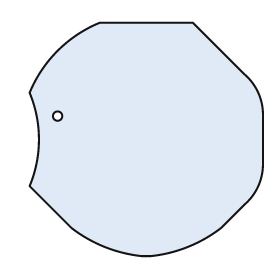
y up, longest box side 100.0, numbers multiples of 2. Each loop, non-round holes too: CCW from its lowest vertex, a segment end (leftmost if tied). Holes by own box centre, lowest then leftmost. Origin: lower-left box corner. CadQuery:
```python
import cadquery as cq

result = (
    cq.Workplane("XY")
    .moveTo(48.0, 0.0)
    .lineTo(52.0, 0.0)
    .threePointArc((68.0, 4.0), (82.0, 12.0))
    .lineTo(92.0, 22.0)
    .threePointArc((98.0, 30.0), (100.0, 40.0))
    .lineTo(100.0, 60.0)
    .threePointArc((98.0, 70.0), (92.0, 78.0))
    .lineTo(70.0, 100.0)
    .lineTo(30.0, 100.0)
    .threePointArc((12.0, 88.0), (0.0, 70.0))
    .threePointArc((4.0, 50.0), (0.0, 30.0))
    .lineTo(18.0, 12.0)
    .threePointArc((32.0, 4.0), (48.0, 0.0))
    .close()
    .moveTo(12.0, 60.0)
    .circle(2.0)
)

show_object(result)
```